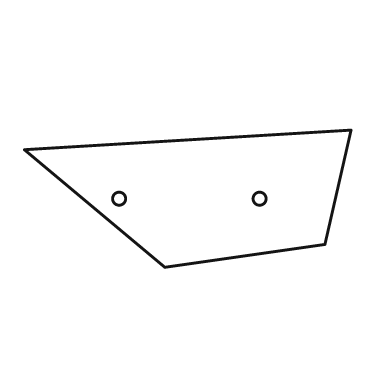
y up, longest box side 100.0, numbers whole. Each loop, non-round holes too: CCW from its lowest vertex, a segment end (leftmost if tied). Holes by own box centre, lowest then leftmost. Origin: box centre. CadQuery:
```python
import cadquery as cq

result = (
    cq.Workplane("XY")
    .moveTo(-7.0, -21.0)
    .lineTo(42.0, -14.0)
    .lineTo(50.0, 21.0)
    .lineTo(-50.0, 15.0)
    .close()
    .moveTo(-21.0, 0.0)
    .circle(2.0)
    .moveTo(22.0, 0.0)
    .circle(2.0)
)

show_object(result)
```